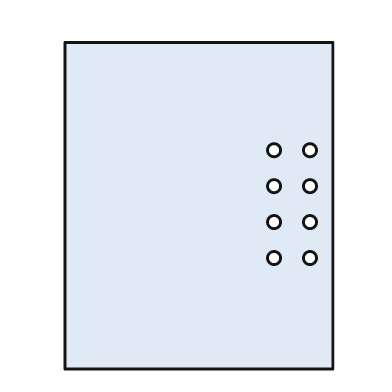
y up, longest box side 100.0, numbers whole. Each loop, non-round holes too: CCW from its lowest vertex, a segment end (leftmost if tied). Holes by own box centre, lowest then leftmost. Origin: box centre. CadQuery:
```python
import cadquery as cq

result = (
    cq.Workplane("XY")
    .moveTo(-41.0, -50.0)
    .lineTo(41.0, -50.0)
    .lineTo(41.0, 50.0)
    .lineTo(-41.0, 50.0)
    .close()
    .moveTo(23.0, -16.0)
    .circle(2.0)
    .moveTo(34.0, -16.0)
    .circle(2.0)
    .moveTo(23.0, -5.0)
    .circle(2.0)
    .moveTo(34.0, -5.0)
    .circle(2.0)
    .moveTo(23.0, 6.0)
    .circle(2.0)
    .moveTo(34.0, 6.0)
    .circle(2.0)
    .moveTo(23.0, 17.0)
    .circle(2.0)
    .moveTo(34.0, 17.0)
    .circle(2.0)
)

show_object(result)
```